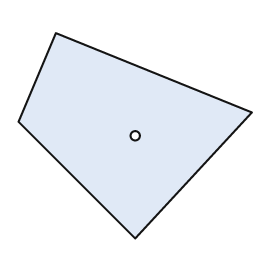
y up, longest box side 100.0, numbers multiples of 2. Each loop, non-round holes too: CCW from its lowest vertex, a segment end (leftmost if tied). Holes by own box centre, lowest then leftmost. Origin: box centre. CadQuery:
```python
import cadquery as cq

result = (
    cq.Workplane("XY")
    .moveTo(0.0, -44.0)
    .lineTo(50.0, 10.0)
    .lineTo(-34.0, 44.0)
    .lineTo(-50.0, 6.0)
    .close()
    .moveTo(0.0, 0.0)
    .circle(2.0)
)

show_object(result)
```